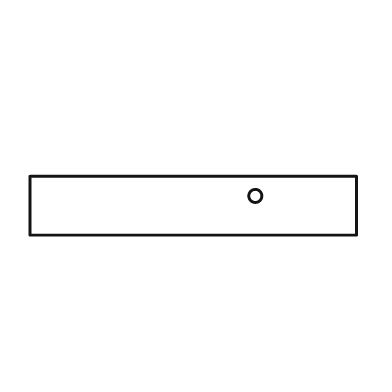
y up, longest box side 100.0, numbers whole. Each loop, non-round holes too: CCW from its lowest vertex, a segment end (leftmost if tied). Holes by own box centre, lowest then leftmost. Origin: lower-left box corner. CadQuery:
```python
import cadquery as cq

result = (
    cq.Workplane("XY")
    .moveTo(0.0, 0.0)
    .lineTo(100.0, 0.0)
    .lineTo(100.0, 18.0)
    .lineTo(0.0, 18.0)
    .close()
    .moveTo(69.0, 12.0)
    .circle(2.0)
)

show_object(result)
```